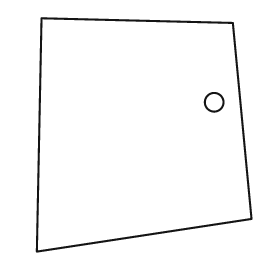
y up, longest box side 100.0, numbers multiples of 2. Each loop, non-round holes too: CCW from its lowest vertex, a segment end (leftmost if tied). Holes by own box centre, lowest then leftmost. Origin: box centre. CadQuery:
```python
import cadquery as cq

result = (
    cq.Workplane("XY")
    .moveTo(-46.0, -50.0)
    .lineTo(46.0, -36.0)
    .lineTo(38.0, 48.0)
    .lineTo(-44.0, 50.0)
    .close()
    .moveTo(30.0, 14.0)
    .circle(4.0)
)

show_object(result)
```